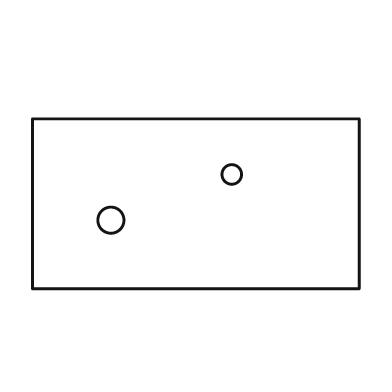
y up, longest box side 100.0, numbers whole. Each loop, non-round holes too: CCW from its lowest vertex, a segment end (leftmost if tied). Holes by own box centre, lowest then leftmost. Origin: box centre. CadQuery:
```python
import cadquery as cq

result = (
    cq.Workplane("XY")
    .moveTo(-50.0, -26.0)
    .lineTo(50.0, -26.0)
    .lineTo(50.0, 26.0)
    .lineTo(-50.0, 26.0)
    .close()
    .moveTo(-26.0, -5.0)
    .circle(4.0)
    .moveTo(11.0, 9.0)
    .circle(3.0)
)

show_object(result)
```